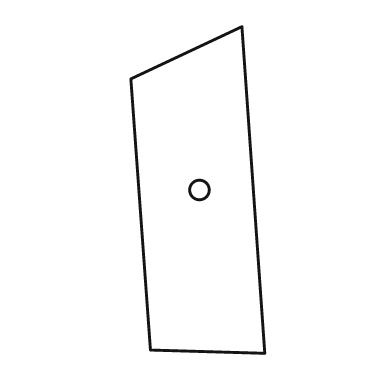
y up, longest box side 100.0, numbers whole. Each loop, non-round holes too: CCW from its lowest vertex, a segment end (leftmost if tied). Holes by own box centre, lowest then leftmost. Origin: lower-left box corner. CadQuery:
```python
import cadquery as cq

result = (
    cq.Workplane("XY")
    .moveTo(41.0, 0.0)
    .lineTo(34.0, 100.0)
    .lineTo(0.0, 84.0)
    .lineTo(6.0, 1.0)
    .close()
    .moveTo(21.0, 50.0)
    .circle(3.0)
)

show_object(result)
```